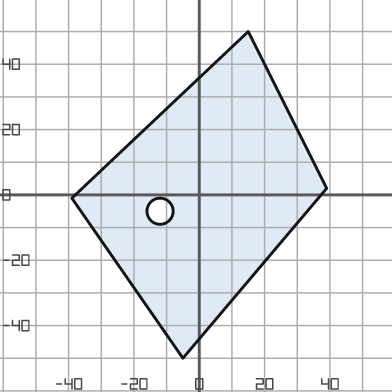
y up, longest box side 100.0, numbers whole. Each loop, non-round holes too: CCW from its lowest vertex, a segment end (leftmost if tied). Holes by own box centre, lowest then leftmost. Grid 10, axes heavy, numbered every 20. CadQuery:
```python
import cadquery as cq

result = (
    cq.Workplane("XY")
    .moveTo(-5.0, -50.0)
    .lineTo(39.0, 2.0)
    .lineTo(15.0, 50.0)
    .lineTo(-39.0, -1.0)
    .close()
    .moveTo(-12.0, -5.0)
    .circle(4.0)
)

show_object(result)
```